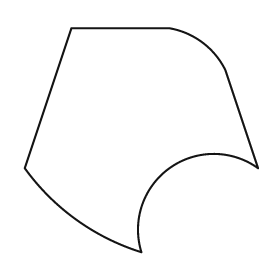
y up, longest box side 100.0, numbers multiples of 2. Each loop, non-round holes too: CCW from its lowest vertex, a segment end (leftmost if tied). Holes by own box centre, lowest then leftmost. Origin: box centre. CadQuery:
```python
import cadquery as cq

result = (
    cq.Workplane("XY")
    .moveTo(0.0, -48.0)
    .threePointArc((12.0, -12.0), (50.0, -12.0))
    .lineTo(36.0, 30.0)
    .threePointArc((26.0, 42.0), (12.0, 48.0))
    .lineTo(-30.0, 48.0)
    .lineTo(-50.0, -12.0)
    .threePointArc((-28.0, -34.0), (0.0, -48.0))
    .close()
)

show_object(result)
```